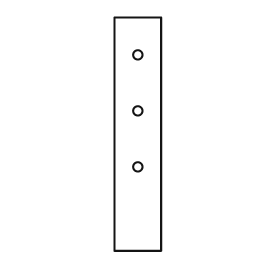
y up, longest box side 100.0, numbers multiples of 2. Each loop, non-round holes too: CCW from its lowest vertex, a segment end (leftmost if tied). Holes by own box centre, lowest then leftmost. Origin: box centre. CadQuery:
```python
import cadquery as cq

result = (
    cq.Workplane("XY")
    .moveTo(-10.0, -50.0)
    .lineTo(10.0, -50.0)
    .lineTo(10.0, 50.0)
    .lineTo(-10.0, 50.0)
    .close()
    .moveTo(0.0, -14.0)
    .circle(2.0)
    .moveTo(0.0, 10.0)
    .circle(2.0)
    .moveTo(0.0, 34.0)
    .circle(2.0)
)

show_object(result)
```